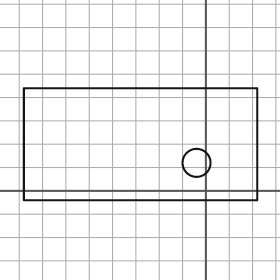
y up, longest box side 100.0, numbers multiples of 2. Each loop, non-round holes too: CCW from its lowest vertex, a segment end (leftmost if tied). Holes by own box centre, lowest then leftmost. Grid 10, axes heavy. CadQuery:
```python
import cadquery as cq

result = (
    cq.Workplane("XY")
    .moveTo(-78.0, -4.0)
    .lineTo(22.0, -4.0)
    .lineTo(22.0, 44.0)
    .lineTo(-78.0, 44.0)
    .close()
    .moveTo(-4.0, 12.0)
    .circle(6.0)
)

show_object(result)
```